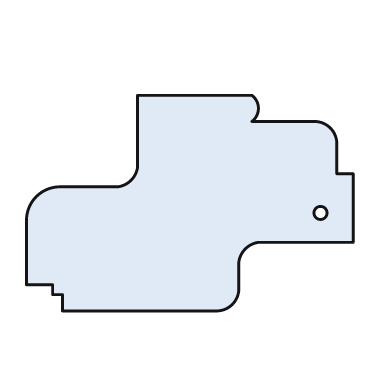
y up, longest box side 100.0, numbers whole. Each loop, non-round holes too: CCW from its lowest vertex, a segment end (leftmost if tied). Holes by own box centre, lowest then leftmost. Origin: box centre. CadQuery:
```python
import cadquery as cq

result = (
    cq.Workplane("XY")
    .moveTo(-39.0, -33.0)
    .lineTo(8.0, -33.0)
    .threePointArc((13.0, -31.0), (15.0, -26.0))
    .lineTo(15.0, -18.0)
    .threePointArc((17.0, -14.0), (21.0, -12.0))
    .lineTo(50.0, -12.0)
    .lineTo(50.0, 9.0)
    .lineTo(45.0, 9.0)
    .lineTo(45.0, 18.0)
    .threePointArc((43.0, 23.0), (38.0, 25.0))
    .lineTo(19.0, 25.0)
    .threePointArc((21.0, 29.0), (19.0, 33.0))
    .lineTo(-16.0, 33.0)
    .lineTo(-16.0, 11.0)
    .threePointArc((-18.0, 7.0), (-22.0, 5.0))
    .lineTo(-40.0, 5.0)
    .threePointArc((-47.0, 2.0), (-50.0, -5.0))
    .lineTo(-50.0, -25.0)
    .lineTo(-42.0, -25.0)
    .lineTo(-42.0, -28.0)
    .lineTo(-39.0, -28.0)
    .close()
    .moveTo(40.0, -3.0)
    .circle(2.0)
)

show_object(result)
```